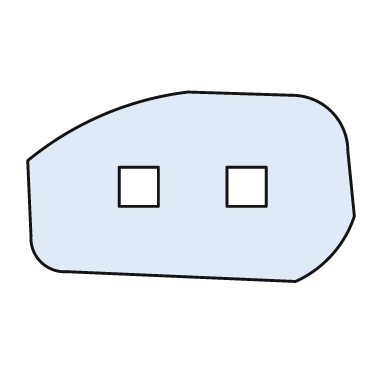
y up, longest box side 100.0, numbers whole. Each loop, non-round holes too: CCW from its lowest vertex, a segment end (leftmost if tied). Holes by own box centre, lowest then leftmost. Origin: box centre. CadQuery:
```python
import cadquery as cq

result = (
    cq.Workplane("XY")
    .moveTo(32.0, -29.0)
    .threePointArc((43.0, -21.0), (50.0, -9.0))
    .lineTo(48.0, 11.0)
    .threePointArc((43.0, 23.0), (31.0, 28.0))
    .lineTo(-1.0, 29.0)
    .threePointArc((-27.0, 22.0), (-50.0, 8.0))
    .lineTo(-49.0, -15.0)
    .threePointArc((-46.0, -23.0), (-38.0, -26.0))
    .close()
    .moveTo(-22.0, -6.0)
    .lineTo(-10.0, -6.0)
    .lineTo(-10.0, 6.0)
    .lineTo(-22.0, 6.0)
    .close()
    .moveTo(11.0, -6.0)
    .lineTo(23.0, -6.0)
    .lineTo(23.0, 6.0)
    .lineTo(11.0, 6.0)
    .close()
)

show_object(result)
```